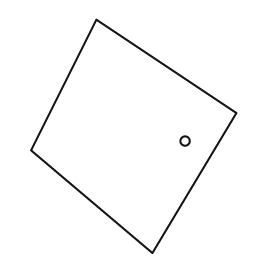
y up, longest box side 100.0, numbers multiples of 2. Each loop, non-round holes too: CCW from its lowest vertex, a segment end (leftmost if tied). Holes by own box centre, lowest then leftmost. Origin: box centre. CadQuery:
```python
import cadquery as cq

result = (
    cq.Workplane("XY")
    .moveTo(8.0, -50.0)
    .lineTo(44.0, 10.0)
    .lineTo(-16.0, 50.0)
    .lineTo(-44.0, -6.0)
    .close()
    .moveTo(22.0, -2.0)
    .circle(2.0)
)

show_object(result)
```